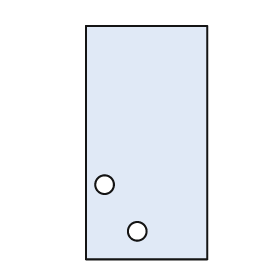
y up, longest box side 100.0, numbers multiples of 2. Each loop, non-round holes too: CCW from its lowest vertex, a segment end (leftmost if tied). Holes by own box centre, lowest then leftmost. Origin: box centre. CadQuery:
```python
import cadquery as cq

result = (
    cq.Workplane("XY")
    .moveTo(-26.0, -50.0)
    .lineTo(26.0, -50.0)
    .lineTo(26.0, 50.0)
    .lineTo(-26.0, 50.0)
    .close()
    .moveTo(-4.0, -38.0)
    .circle(4.0)
    .moveTo(-18.0, -18.0)
    .circle(4.0)
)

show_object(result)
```